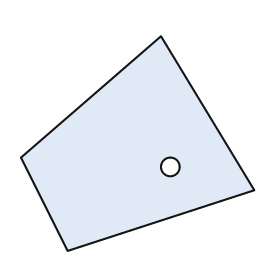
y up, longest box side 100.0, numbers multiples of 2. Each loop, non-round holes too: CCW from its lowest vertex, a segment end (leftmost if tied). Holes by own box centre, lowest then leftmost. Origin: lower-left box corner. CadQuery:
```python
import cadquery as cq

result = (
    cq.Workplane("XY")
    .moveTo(20.0, 0.0)
    .lineTo(100.0, 26.0)
    .lineTo(60.0, 92.0)
    .lineTo(0.0, 40.0)
    .close()
    .moveTo(64.0, 36.0)
    .circle(4.0)
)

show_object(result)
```